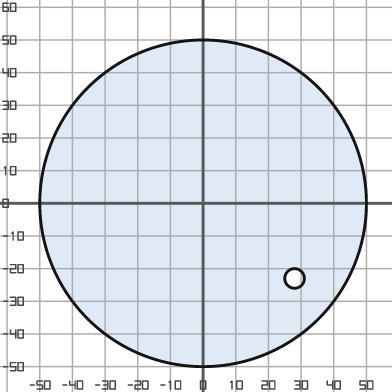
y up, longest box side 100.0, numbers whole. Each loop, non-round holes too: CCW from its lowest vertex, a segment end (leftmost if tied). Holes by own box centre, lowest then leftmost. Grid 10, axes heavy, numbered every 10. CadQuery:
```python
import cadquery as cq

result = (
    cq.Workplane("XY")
    .moveTo(0.0, 0.0)
    .circle(50.0)
    .moveTo(28.0, -23.0)
    .circle(3.0)
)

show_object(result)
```